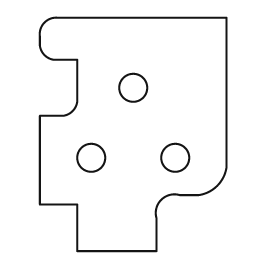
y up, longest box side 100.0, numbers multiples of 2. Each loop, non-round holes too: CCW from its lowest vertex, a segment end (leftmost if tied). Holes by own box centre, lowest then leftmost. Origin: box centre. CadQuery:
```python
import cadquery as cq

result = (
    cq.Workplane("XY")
    .moveTo(-24.0, -50.0)
    .lineTo(10.0, -50.0)
    .lineTo(10.0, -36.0)
    .threePointArc((12.0, -28.0), (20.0, -26.0))
    .lineTo(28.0, -26.0)
    .threePointArc((36.0, -22.0), (40.0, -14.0))
    .lineTo(40.0, 50.0)
    .lineTo(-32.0, 50.0)
    .threePointArc((-38.0, 48.0), (-40.0, 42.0))
    .lineTo(-40.0, 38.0)
    .threePointArc((-38.0, 34.0), (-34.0, 32.0))
    .lineTo(-24.0, 32.0)
    .lineTo(-24.0, 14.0)
    .threePointArc((-26.0, 10.0), (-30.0, 8.0))
    .lineTo(-40.0, 8.0)
    .lineTo(-40.0, -30.0)
    .lineTo(-24.0, -30.0)
    .close()
    .moveTo(-18.0, -10.0)
    .circle(6.0)
    .moveTo(18.0, -10.0)
    .circle(6.0)
    .moveTo(0.0, 20.0)
    .circle(6.0)
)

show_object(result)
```